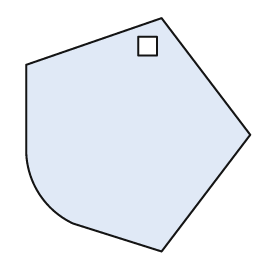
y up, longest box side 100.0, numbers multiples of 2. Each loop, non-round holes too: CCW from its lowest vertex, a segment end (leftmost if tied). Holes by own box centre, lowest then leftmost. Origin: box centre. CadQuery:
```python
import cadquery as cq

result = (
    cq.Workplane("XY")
    .moveTo(10.0, -50.0)
    .lineTo(48.0, 0.0)
    .lineTo(10.0, 50.0)
    .lineTo(-48.0, 30.0)
    .lineTo(-48.0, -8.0)
    .threePointArc((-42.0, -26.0), (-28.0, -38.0))
    .close()
    .moveTo(0.0, 34.0)
    .lineTo(8.0, 34.0)
    .lineTo(8.0, 42.0)
    .lineTo(0.0, 42.0)
    .close()
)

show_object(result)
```